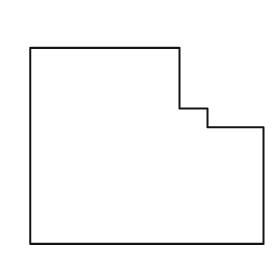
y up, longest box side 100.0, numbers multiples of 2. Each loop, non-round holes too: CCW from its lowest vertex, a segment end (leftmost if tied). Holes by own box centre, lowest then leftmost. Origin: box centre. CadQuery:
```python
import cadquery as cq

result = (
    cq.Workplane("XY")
    .moveTo(-50.0, -42.0)
    .lineTo(50.0, -42.0)
    .lineTo(50.0, 8.0)
    .lineTo(26.0, 8.0)
    .lineTo(26.0, 16.0)
    .lineTo(14.0, 16.0)
    .lineTo(14.0, 42.0)
    .lineTo(-50.0, 42.0)
    .close()
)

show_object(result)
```